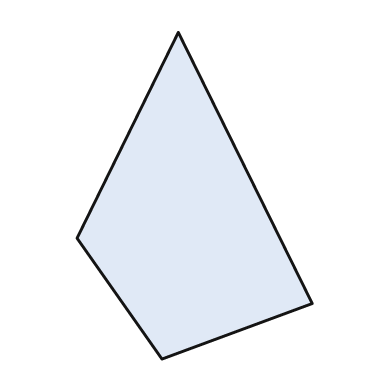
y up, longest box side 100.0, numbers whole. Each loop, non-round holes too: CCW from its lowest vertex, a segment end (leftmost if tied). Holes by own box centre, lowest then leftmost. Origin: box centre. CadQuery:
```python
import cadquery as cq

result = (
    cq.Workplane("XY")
    .moveTo(-10.0, -50.0)
    .lineTo(36.0, -33.0)
    .lineTo(-5.0, 50.0)
    .lineTo(-36.0, -13.0)
    .close()
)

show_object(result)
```